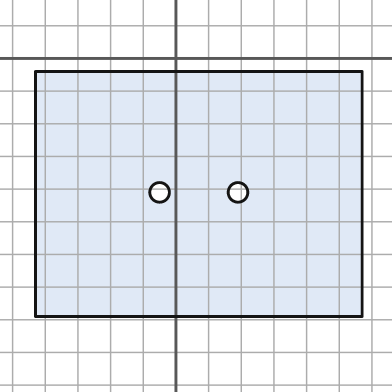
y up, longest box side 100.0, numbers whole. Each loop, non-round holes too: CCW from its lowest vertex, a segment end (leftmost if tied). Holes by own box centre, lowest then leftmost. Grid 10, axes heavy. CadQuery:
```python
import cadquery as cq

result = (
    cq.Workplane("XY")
    .moveTo(-43.0, -79.0)
    .lineTo(57.0, -79.0)
    .lineTo(57.0, -4.0)
    .lineTo(-43.0, -4.0)
    .close()
    .moveTo(-5.0, -41.0)
    .circle(3.0)
    .moveTo(19.0, -41.0)
    .circle(3.0)
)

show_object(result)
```